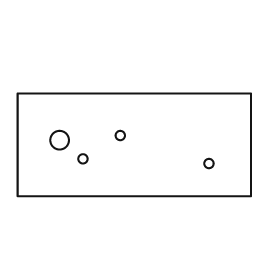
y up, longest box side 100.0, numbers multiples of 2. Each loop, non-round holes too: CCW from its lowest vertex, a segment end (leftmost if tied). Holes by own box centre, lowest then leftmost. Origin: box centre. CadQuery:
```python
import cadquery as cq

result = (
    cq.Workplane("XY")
    .moveTo(-50.0, -22.0)
    .lineTo(50.0, -22.0)
    .lineTo(50.0, 22.0)
    .lineTo(-50.0, 22.0)
    .close()
    .moveTo(32.0, -8.0)
    .circle(2.0)
    .moveTo(-22.0, -6.0)
    .circle(2.0)
    .moveTo(-32.0, 2.0)
    .circle(4.0)
    .moveTo(-6.0, 4.0)
    .circle(2.0)
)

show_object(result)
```